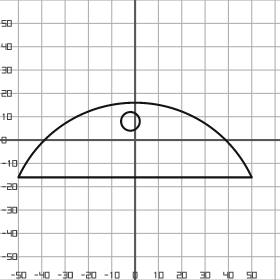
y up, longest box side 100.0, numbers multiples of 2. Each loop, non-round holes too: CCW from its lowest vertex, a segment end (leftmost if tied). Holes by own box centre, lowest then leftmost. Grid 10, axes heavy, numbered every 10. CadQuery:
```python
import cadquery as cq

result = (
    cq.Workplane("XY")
    .moveTo(-50.0, -16.0)
    .lineTo(50.0, -16.0)
    .threePointArc((0.0, 16.0), (-50.0, -16.0))
    .close()
    .moveTo(-2.0, 8.0)
    .circle(4.0)
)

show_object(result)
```